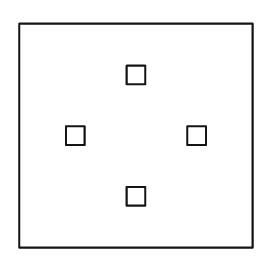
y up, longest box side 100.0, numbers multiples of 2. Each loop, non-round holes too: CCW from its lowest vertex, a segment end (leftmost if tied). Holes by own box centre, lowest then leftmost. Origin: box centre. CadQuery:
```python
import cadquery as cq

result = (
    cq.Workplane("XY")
    .moveTo(-50.0, -48.0)
    .lineTo(50.0, -48.0)
    .lineTo(50.0, 48.0)
    .lineTo(-50.0, 48.0)
    .close()
    .moveTo(-4.0, -30.0)
    .lineTo(4.0, -30.0)
    .lineTo(4.0, -22.0)
    .lineTo(-4.0, -22.0)
    .close()
    .moveTo(-30.0, -4.0)
    .lineTo(-22.0, -4.0)
    .lineTo(-22.0, 4.0)
    .lineTo(-30.0, 4.0)
    .close()
    .moveTo(22.0, -4.0)
    .lineTo(30.0, -4.0)
    .lineTo(30.0, 4.0)
    .lineTo(22.0, 4.0)
    .close()
    .moveTo(-4.0, 22.0)
    .lineTo(4.0, 22.0)
    .lineTo(4.0, 30.0)
    .lineTo(-4.0, 30.0)
    .close()
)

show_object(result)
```